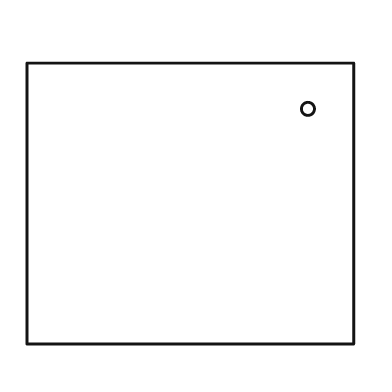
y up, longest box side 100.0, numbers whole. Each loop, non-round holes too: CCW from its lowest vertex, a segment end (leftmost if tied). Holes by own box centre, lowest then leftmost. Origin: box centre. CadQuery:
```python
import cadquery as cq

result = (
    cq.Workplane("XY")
    .moveTo(-50.0, -43.0)
    .lineTo(50.0, -43.0)
    .lineTo(50.0, 43.0)
    .lineTo(-50.0, 43.0)
    .close()
    .moveTo(36.0, 29.0)
    .circle(2.0)
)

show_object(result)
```